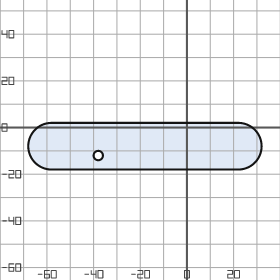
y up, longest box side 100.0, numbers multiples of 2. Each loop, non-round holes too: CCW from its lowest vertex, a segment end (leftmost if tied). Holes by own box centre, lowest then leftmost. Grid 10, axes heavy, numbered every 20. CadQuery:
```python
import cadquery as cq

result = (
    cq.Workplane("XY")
    .moveTo(-58.0, -18.0)
    .lineTo(22.0, -18.0)
    .threePointArc((32.0, -8.0), (22.0, 2.0))
    .lineTo(-58.0, 2.0)
    .threePointArc((-68.0, -8.0), (-58.0, -18.0))
    .close()
    .moveTo(-38.0, -12.0)
    .circle(2.0)
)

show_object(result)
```